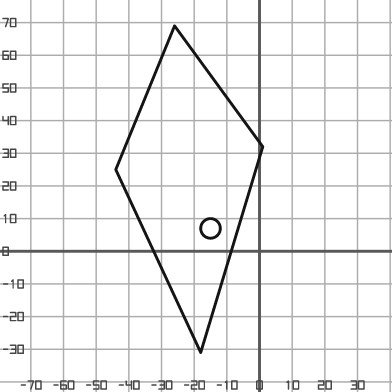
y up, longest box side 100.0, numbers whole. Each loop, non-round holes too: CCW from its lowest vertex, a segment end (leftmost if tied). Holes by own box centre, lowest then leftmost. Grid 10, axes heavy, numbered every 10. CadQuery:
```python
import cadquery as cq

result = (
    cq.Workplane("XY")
    .moveTo(-18.0, -31.0)
    .lineTo(1.0, 32.0)
    .lineTo(-26.0, 69.0)
    .lineTo(-44.0, 25.0)
    .close()
    .moveTo(-15.0, 7.0)
    .circle(3.0)
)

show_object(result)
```